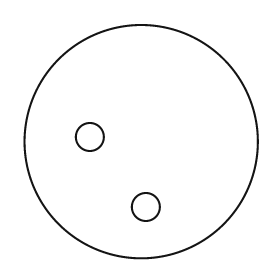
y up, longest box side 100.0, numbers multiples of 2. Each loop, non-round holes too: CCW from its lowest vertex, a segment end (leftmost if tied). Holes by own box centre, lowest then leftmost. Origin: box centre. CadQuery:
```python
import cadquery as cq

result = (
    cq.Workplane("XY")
    .moveTo(0.0, 0.0)
    .circle(50.0)
    .moveTo(2.0, -28.0)
    .circle(6.0)
    .moveTo(-22.0, 2.0)
    .circle(6.0)
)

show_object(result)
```